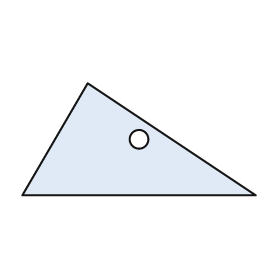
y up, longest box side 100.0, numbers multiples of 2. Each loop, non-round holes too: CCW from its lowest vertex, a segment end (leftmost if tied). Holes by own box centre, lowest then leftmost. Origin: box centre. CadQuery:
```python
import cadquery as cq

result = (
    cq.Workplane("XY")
    .moveTo(-50.0, -24.0)
    .lineTo(50.0, -24.0)
    .lineTo(-22.0, 24.0)
    .close()
    .moveTo(0.0, 0.0)
    .circle(4.0)
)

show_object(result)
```